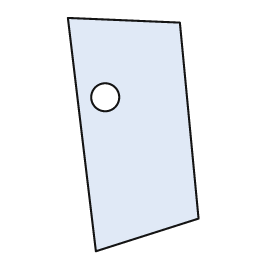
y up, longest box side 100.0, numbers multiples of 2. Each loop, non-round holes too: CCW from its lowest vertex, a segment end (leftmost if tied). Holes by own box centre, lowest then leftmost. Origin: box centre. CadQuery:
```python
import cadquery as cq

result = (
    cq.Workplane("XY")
    .moveTo(-16.0, -50.0)
    .lineTo(28.0, -36.0)
    .lineTo(20.0, 48.0)
    .lineTo(-28.0, 50.0)
    .close()
    .moveTo(-12.0, 16.0)
    .circle(6.0)
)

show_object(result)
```